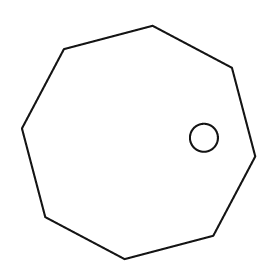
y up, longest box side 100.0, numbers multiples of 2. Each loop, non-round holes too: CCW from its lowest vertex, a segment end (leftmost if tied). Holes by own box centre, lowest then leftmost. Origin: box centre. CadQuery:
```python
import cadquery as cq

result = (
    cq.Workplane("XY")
    .moveTo(-6.0, -50.0)
    .lineTo(32.0, -40.0)
    .lineTo(50.0, -6.0)
    .lineTo(40.0, 32.0)
    .lineTo(6.0, 50.0)
    .lineTo(-32.0, 40.0)
    .lineTo(-50.0, 6.0)
    .lineTo(-40.0, -32.0)
    .close()
    .moveTo(28.0, 2.0)
    .circle(6.0)
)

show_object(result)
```